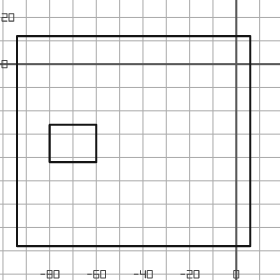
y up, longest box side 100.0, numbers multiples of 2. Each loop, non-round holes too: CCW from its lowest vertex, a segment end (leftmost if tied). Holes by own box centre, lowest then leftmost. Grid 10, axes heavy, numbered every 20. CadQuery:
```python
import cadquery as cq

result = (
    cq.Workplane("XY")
    .moveTo(-94.0, -78.0)
    .lineTo(6.0, -78.0)
    .lineTo(6.0, 12.0)
    .lineTo(-94.0, 12.0)
    .close()
    .moveTo(-80.0, -42.0)
    .lineTo(-60.0, -42.0)
    .lineTo(-60.0, -26.0)
    .lineTo(-80.0, -26.0)
    .close()
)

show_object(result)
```